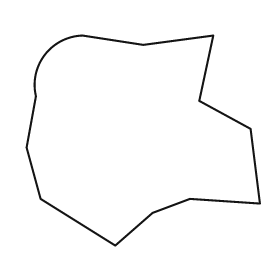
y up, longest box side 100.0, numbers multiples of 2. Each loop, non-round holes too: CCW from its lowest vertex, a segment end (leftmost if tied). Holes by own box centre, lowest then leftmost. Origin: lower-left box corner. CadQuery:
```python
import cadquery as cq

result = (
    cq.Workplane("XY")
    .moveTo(38.0, 0.0)
    .lineTo(54.0, 14.0)
    .lineTo(70.0, 20.0)
    .lineTo(100.0, 18.0)
    .lineTo(96.0, 50.0)
    .lineTo(74.0, 62.0)
    .lineTo(80.0, 90.0)
    .lineTo(50.0, 86.0)
    .lineTo(24.0, 90.0)
    .threePointArc((8.0, 82.0), (4.0, 64.0))
    .lineTo(0.0, 42.0)
    .lineTo(6.0, 20.0)
    .close()
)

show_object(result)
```